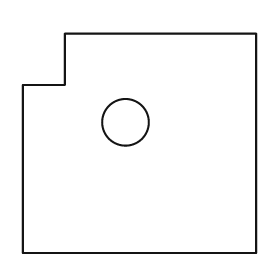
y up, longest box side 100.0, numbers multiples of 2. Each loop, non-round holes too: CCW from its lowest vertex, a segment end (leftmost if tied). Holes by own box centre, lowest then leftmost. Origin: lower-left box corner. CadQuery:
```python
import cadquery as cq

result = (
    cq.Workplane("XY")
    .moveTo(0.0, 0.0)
    .lineTo(100.0, 0.0)
    .lineTo(100.0, 94.0)
    .lineTo(18.0, 94.0)
    .lineTo(18.0, 72.0)
    .lineTo(0.0, 72.0)
    .close()
    .moveTo(44.0, 56.0)
    .circle(10.0)
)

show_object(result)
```